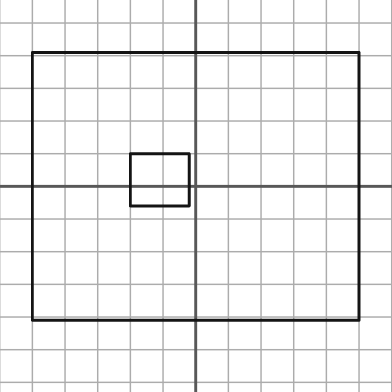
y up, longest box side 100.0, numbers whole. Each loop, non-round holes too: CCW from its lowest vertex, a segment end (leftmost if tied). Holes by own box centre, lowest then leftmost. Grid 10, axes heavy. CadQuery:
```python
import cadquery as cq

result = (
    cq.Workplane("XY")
    .moveTo(-50.0, -41.0)
    .lineTo(50.0, -41.0)
    .lineTo(50.0, 41.0)
    .lineTo(-50.0, 41.0)
    .close()
    .moveTo(-20.0, -6.0)
    .lineTo(-2.0, -6.0)
    .lineTo(-2.0, 10.0)
    .lineTo(-20.0, 10.0)
    .close()
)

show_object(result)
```